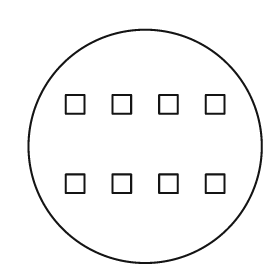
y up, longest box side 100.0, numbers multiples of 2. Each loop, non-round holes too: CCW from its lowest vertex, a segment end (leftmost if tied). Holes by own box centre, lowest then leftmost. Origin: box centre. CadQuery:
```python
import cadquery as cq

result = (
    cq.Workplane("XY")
    .moveTo(0.0, 0.0)
    .circle(50.0)
    .moveTo(-34.0, -20.0)
    .lineTo(-26.0, -20.0)
    .lineTo(-26.0, -12.0)
    .lineTo(-34.0, -12.0)
    .close()
    .moveTo(-14.0, -20.0)
    .lineTo(-6.0, -20.0)
    .lineTo(-6.0, -12.0)
    .lineTo(-14.0, -12.0)
    .close()
    .moveTo(6.0, -20.0)
    .lineTo(14.0, -20.0)
    .lineTo(14.0, -12.0)
    .lineTo(6.0, -12.0)
    .close()
    .moveTo(26.0, -20.0)
    .lineTo(34.0, -20.0)
    .lineTo(34.0, -12.0)
    .lineTo(26.0, -12.0)
    .close()
    .moveTo(-34.0, 14.0)
    .lineTo(-26.0, 14.0)
    .lineTo(-26.0, 22.0)
    .lineTo(-34.0, 22.0)
    .close()
    .moveTo(-14.0, 14.0)
    .lineTo(-6.0, 14.0)
    .lineTo(-6.0, 22.0)
    .lineTo(-14.0, 22.0)
    .close()
    .moveTo(6.0, 14.0)
    .lineTo(14.0, 14.0)
    .lineTo(14.0, 22.0)
    .lineTo(6.0, 22.0)
    .close()
    .moveTo(26.0, 14.0)
    .lineTo(34.0, 14.0)
    .lineTo(34.0, 22.0)
    .lineTo(26.0, 22.0)
    .close()
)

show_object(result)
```